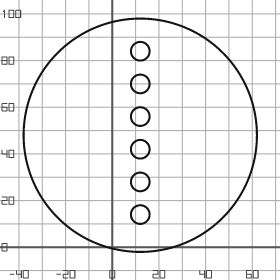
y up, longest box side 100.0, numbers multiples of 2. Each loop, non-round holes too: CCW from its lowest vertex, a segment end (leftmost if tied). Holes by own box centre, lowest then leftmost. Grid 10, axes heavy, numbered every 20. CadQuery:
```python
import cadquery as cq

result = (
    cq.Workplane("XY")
    .moveTo(12.0, 48.0)
    .circle(50.0)
    .moveTo(12.0, 14.0)
    .circle(4.0)
    .moveTo(12.0, 28.0)
    .circle(4.0)
    .moveTo(12.0, 42.0)
    .circle(4.0)
    .moveTo(12.0, 56.0)
    .circle(4.0)
    .moveTo(12.0, 70.0)
    .circle(4.0)
    .moveTo(12.0, 84.0)
    .circle(4.0)
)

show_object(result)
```